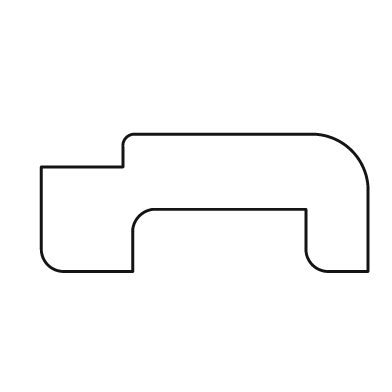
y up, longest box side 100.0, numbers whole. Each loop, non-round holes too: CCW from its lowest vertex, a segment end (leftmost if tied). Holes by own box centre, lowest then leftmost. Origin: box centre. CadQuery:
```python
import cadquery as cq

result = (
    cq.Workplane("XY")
    .moveTo(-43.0, -21.0)
    .lineTo(-22.0, -21.0)
    .lineTo(-22.0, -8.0)
    .threePointArc((-20.0, -4.0), (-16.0, -2.0))
    .lineTo(31.0, -2.0)
    .lineTo(31.0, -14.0)
    .threePointArc((33.0, -19.0), (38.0, -21.0))
    .lineTo(50.0, -21.0)
    .lineTo(50.0, 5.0)
    .threePointArc((45.0, 16.0), (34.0, 21.0))
    .lineTo(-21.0, 21.0)
    .threePointArc((-24.0, 20.0), (-25.0, 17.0))
    .lineTo(-25.0, 11.0)
    .lineTo(-50.0, 11.0)
    .lineTo(-50.0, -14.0)
    .threePointArc((-48.0, -19.0), (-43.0, -21.0))
    .close()
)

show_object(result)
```